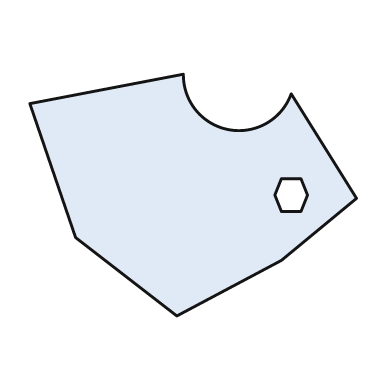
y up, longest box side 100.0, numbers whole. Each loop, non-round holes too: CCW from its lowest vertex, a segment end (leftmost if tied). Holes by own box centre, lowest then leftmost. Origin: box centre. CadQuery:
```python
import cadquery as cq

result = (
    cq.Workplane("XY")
    .moveTo(-5.0, -37.0)
    .lineTo(27.0, -20.0)
    .lineTo(50.0, -1.0)
    .lineTo(30.0, 31.0)
    .threePointArc((11.0, 20.0), (-3.0, 37.0))
    .lineTo(-50.0, 28.0)
    .lineTo(-36.0, -13.0)
    .close()
    .moveTo(27.0, -5.0)
    .lineTo(33.0, -5.0)
    .lineTo(35.0, 0.0)
    .lineTo(33.0, 5.0)
    .lineTo(27.0, 5.0)
    .lineTo(25.0, 0.0)
    .close()
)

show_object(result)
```